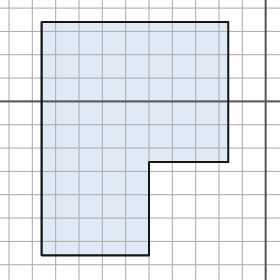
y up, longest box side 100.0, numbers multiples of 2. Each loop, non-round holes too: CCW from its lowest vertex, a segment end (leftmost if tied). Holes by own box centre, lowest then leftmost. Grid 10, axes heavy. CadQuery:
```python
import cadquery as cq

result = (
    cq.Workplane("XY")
    .moveTo(-96.0, -66.0)
    .lineTo(-50.0, -66.0)
    .lineTo(-50.0, -26.0)
    .lineTo(-16.0, -26.0)
    .lineTo(-16.0, 34.0)
    .lineTo(-96.0, 34.0)
    .close()
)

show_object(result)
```